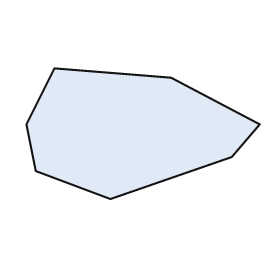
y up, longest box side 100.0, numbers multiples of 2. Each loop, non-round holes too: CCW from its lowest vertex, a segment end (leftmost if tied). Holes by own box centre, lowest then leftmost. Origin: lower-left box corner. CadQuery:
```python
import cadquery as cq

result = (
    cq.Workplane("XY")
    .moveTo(36.0, 0.0)
    .lineTo(88.0, 18.0)
    .lineTo(100.0, 32.0)
    .lineTo(62.0, 52.0)
    .lineTo(12.0, 56.0)
    .lineTo(0.0, 32.0)
    .lineTo(4.0, 12.0)
    .close()
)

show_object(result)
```